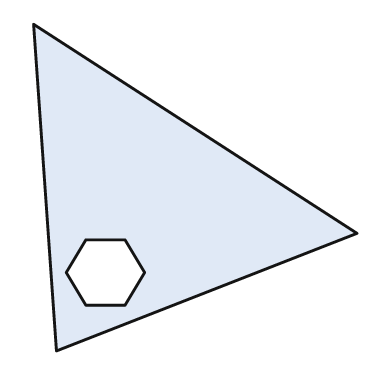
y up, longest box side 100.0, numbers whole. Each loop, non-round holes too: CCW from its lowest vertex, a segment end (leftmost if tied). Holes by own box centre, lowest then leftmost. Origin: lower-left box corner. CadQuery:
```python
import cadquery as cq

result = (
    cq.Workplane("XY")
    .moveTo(7.0, 0.0)
    .lineTo(99.0, 36.0)
    .lineTo(0.0, 100.0)
    .close()
    .moveTo(16.0, 14.0)
    .lineTo(28.0, 14.0)
    .lineTo(34.0, 24.0)
    .lineTo(28.0, 34.0)
    .lineTo(16.0, 34.0)
    .lineTo(10.0, 24.0)
    .close()
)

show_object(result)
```